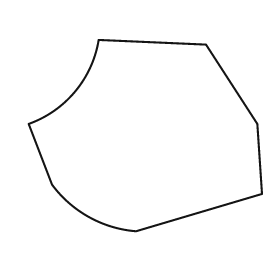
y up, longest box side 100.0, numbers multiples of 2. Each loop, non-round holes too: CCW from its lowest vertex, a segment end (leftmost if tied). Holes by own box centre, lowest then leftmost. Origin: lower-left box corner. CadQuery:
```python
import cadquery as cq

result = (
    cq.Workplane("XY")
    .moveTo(46.0, 0.0)
    .lineTo(100.0, 16.0)
    .lineTo(98.0, 46.0)
    .lineTo(76.0, 80.0)
    .lineTo(30.0, 82.0)
    .threePointArc((20.0, 60.0), (0.0, 46.0))
    .lineTo(10.0, 20.0)
    .threePointArc((26.0, 6.0), (46.0, 0.0))
    .close()
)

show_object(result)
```